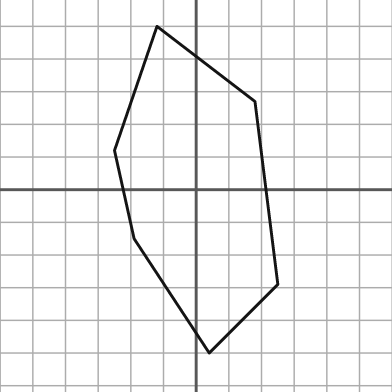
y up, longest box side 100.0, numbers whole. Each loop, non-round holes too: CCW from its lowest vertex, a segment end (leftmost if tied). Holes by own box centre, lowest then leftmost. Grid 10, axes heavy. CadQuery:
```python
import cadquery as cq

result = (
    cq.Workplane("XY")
    .moveTo(4.0, -50.0)
    .lineTo(25.0, -29.0)
    .lineTo(18.0, 27.0)
    .lineTo(-12.0, 50.0)
    .lineTo(-25.0, 12.0)
    .lineTo(-19.0, -15.0)
    .close()
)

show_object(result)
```